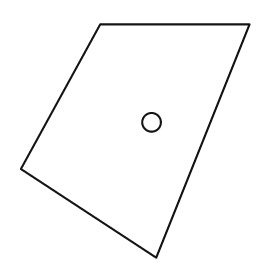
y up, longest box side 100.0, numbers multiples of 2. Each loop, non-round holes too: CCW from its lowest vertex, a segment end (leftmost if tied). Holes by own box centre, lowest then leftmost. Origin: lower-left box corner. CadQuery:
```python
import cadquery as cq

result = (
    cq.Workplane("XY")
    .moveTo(58.0, 0.0)
    .lineTo(98.0, 100.0)
    .lineTo(34.0, 100.0)
    .lineTo(0.0, 38.0)
    .close()
    .moveTo(56.0, 58.0)
    .circle(4.0)
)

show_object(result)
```